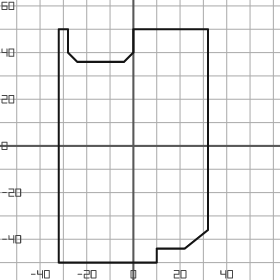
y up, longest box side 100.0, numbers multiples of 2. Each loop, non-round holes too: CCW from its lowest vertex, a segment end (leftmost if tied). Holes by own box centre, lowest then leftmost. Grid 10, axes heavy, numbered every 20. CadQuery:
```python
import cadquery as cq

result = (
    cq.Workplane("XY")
    .moveTo(-32.0, -50.0)
    .lineTo(10.0, -50.0)
    .lineTo(10.0, -44.0)
    .lineTo(22.0, -44.0)
    .lineTo(32.0, -36.0)
    .lineTo(32.0, 50.0)
    .lineTo(0.0, 50.0)
    .lineTo(0.0, 40.0)
    .lineTo(-4.0, 36.0)
    .lineTo(-24.0, 36.0)
    .lineTo(-28.0, 40.0)
    .lineTo(-28.0, 50.0)
    .lineTo(-32.0, 50.0)
    .close()
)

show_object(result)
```